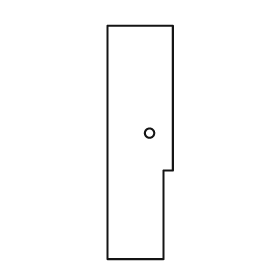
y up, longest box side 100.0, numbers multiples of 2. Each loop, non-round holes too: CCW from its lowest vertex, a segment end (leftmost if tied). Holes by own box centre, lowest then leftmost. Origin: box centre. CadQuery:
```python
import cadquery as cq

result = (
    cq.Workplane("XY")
    .moveTo(-14.0, -50.0)
    .lineTo(10.0, -50.0)
    .lineTo(10.0, -12.0)
    .lineTo(14.0, -12.0)
    .lineTo(14.0, 50.0)
    .lineTo(-14.0, 50.0)
    .close()
    .moveTo(4.0, 4.0)
    .circle(2.0)
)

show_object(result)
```